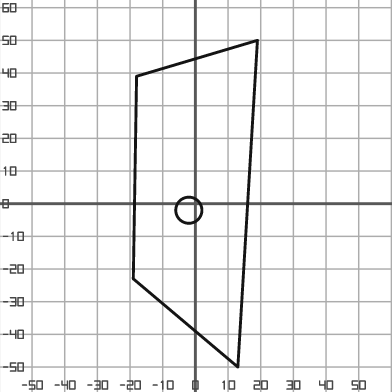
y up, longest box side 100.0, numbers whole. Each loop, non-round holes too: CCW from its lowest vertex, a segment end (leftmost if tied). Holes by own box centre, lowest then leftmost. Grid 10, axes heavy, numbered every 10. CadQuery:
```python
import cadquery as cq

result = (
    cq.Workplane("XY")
    .moveTo(13.0, -50.0)
    .lineTo(19.0, 50.0)
    .lineTo(-18.0, 39.0)
    .lineTo(-19.0, -23.0)
    .close()
    .moveTo(-2.0, -2.0)
    .circle(4.0)
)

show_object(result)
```